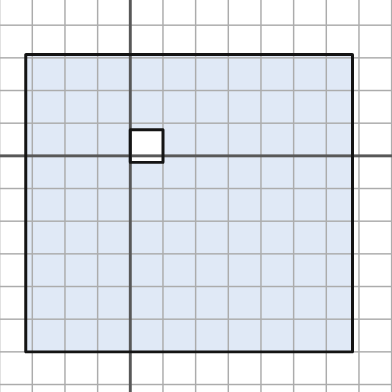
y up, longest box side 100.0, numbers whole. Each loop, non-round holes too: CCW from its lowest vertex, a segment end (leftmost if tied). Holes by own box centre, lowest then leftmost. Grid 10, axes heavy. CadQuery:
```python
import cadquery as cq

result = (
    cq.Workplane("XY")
    .moveTo(-32.0, -60.0)
    .lineTo(68.0, -60.0)
    .lineTo(68.0, 31.0)
    .lineTo(-32.0, 31.0)
    .close()
    .moveTo(0.0, -2.0)
    .lineTo(10.0, -2.0)
    .lineTo(10.0, 8.0)
    .lineTo(0.0, 8.0)
    .close()
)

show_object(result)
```